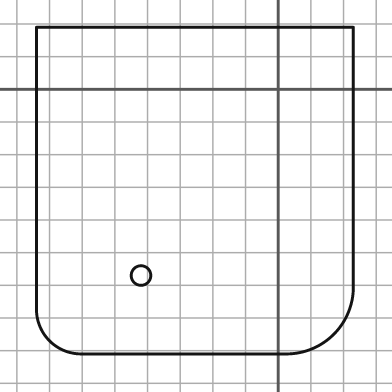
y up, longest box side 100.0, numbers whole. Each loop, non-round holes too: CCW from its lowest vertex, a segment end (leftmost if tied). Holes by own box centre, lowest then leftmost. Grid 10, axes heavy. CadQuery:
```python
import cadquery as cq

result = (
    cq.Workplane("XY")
    .moveTo(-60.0, -81.0)
    .lineTo(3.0, -81.0)
    .threePointArc((17.0, -75.0), (23.0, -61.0))
    .lineTo(23.0, 19.0)
    .lineTo(-74.0, 19.0)
    .lineTo(-74.0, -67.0)
    .threePointArc((-70.0, -77.0), (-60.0, -81.0))
    .close()
    .moveTo(-42.0, -57.0)
    .circle(3.0)
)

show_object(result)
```